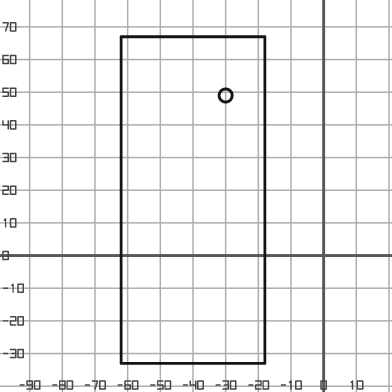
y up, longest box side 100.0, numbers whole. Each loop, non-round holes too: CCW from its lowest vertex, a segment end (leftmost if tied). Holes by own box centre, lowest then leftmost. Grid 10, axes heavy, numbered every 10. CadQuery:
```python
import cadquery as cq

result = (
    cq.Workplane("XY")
    .moveTo(-62.0, -33.0)
    .lineTo(-18.0, -33.0)
    .lineTo(-18.0, 67.0)
    .lineTo(-62.0, 67.0)
    .close()
    .moveTo(-30.0, 49.0)
    .circle(2.0)
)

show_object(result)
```